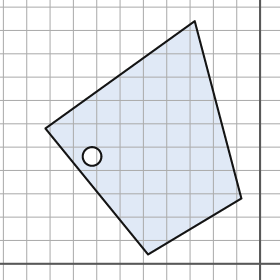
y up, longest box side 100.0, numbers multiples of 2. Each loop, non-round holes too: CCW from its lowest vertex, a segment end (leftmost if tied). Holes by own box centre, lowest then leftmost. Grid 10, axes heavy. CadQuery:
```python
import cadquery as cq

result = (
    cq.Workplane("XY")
    .moveTo(-48.0, 4.0)
    .lineTo(-8.0, 28.0)
    .lineTo(-28.0, 104.0)
    .lineTo(-92.0, 58.0)
    .close()
    .moveTo(-72.0, 46.0)
    .circle(4.0)
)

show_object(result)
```